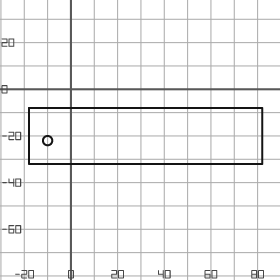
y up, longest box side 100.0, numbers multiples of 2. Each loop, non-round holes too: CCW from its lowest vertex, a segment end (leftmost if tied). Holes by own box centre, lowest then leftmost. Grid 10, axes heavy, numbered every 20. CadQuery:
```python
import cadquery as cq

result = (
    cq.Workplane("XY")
    .moveTo(-18.0, -32.0)
    .lineTo(82.0, -32.0)
    .lineTo(82.0, -8.0)
    .lineTo(-18.0, -8.0)
    .close()
    .moveTo(-10.0, -22.0)
    .circle(2.0)
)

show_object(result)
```